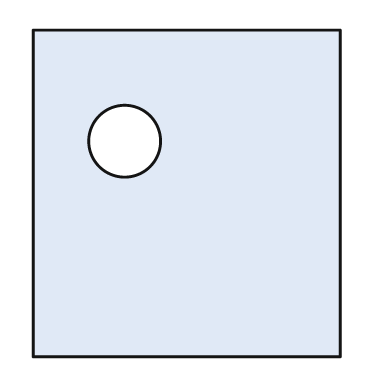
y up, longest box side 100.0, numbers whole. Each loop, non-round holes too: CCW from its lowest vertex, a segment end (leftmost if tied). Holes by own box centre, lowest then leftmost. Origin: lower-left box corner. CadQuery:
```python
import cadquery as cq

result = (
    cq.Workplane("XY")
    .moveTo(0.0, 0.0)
    .lineTo(94.0, 0.0)
    .lineTo(94.0, 100.0)
    .lineTo(0.0, 100.0)
    .close()
    .moveTo(28.0, 66.0)
    .circle(11.0)
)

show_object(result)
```